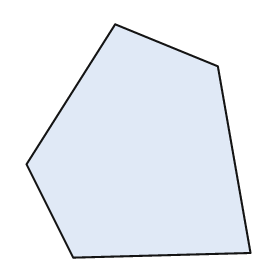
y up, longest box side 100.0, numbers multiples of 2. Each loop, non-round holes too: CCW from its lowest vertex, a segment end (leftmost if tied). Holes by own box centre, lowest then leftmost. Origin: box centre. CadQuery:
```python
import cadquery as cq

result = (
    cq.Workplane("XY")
    .moveTo(-28.0, -50.0)
    .lineTo(48.0, -48.0)
    .lineTo(34.0, 32.0)
    .lineTo(-10.0, 50.0)
    .lineTo(-48.0, -10.0)
    .close()
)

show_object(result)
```